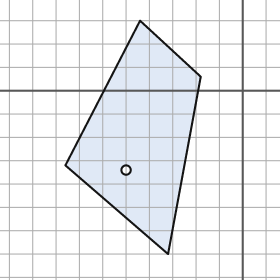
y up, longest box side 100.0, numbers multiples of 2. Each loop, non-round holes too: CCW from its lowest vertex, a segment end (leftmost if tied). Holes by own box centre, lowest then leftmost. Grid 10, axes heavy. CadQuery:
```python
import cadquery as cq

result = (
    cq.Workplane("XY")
    .moveTo(-32.0, -70.0)
    .lineTo(-18.0, 6.0)
    .lineTo(-44.0, 30.0)
    .lineTo(-76.0, -32.0)
    .close()
    .moveTo(-50.0, -34.0)
    .circle(2.0)
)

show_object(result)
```